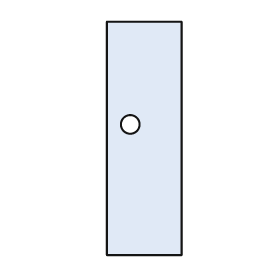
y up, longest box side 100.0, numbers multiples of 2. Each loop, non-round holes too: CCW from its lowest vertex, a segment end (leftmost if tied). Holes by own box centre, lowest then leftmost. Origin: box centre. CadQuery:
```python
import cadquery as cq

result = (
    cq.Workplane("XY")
    .moveTo(-16.0, -50.0)
    .lineTo(16.0, -50.0)
    .lineTo(16.0, 50.0)
    .lineTo(-16.0, 50.0)
    .close()
    .moveTo(-6.0, 6.0)
    .circle(4.0)
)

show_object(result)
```